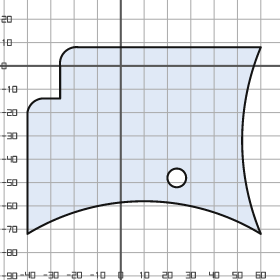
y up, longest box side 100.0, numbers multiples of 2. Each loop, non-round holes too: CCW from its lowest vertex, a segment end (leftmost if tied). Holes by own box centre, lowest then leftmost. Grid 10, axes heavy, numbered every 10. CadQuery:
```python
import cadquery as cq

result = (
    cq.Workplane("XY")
    .moveTo(-40.0, -72.0)
    .threePointArc((10.0, -58.0), (60.0, -72.0))
    .threePointArc((52.0, -32.0), (60.0, 8.0))
    .lineTo(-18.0, 8.0)
    .threePointArc((-24.0, 6.0), (-26.0, 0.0))
    .lineTo(-26.0, -14.0)
    .lineTo(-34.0, -14.0)
    .threePointArc((-38.0, -16.0), (-40.0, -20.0))
    .close()
    .moveTo(24.0, -48.0)
    .circle(4.0)
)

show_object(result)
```